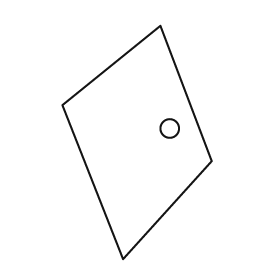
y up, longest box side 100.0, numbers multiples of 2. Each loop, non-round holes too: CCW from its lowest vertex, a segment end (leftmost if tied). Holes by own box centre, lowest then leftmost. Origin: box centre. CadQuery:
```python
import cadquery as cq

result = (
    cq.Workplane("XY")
    .moveTo(-6.0, -50.0)
    .lineTo(32.0, -8.0)
    .lineTo(10.0, 50.0)
    .lineTo(-32.0, 16.0)
    .close()
    .moveTo(14.0, 6.0)
    .circle(4.0)
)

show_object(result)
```